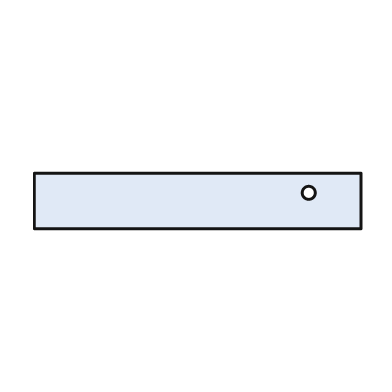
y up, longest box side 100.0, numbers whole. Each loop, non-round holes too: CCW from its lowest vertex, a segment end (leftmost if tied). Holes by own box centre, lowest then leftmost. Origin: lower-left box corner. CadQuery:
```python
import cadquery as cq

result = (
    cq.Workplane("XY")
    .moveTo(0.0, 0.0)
    .lineTo(100.0, 0.0)
    .lineTo(100.0, 17.0)
    .lineTo(0.0, 17.0)
    .close()
    .moveTo(84.0, 11.0)
    .circle(2.0)
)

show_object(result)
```